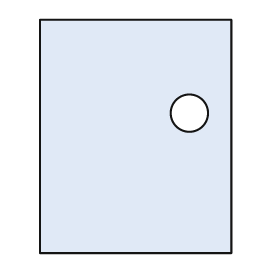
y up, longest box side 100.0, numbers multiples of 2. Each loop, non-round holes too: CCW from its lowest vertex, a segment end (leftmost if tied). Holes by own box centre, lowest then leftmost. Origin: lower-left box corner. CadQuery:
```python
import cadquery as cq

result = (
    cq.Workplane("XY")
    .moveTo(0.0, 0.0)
    .lineTo(82.0, 0.0)
    .lineTo(82.0, 100.0)
    .lineTo(0.0, 100.0)
    .close()
    .moveTo(64.0, 60.0)
    .circle(8.0)
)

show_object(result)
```